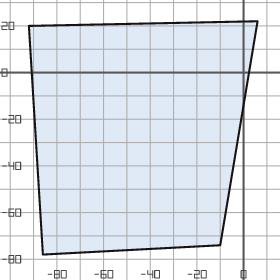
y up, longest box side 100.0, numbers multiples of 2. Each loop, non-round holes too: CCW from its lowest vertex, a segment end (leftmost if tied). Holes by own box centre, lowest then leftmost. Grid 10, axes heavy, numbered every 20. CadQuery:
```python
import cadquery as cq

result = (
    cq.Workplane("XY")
    .moveTo(-86.0, -78.0)
    .lineTo(-10.0, -74.0)
    .lineTo(6.0, 22.0)
    .lineTo(-92.0, 20.0)
    .close()
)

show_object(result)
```